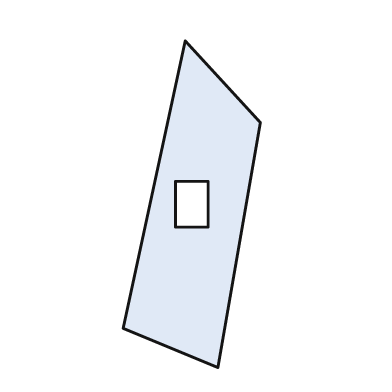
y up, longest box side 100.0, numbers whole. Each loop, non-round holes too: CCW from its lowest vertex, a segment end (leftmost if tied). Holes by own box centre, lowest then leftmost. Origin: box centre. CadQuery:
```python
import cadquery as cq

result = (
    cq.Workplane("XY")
    .moveTo(8.0, -50.0)
    .lineTo(21.0, 25.0)
    .lineTo(-2.0, 50.0)
    .lineTo(-21.0, -38.0)
    .close()
    .moveTo(-5.0, -7.0)
    .lineTo(5.0, -7.0)
    .lineTo(5.0, 7.0)
    .lineTo(-5.0, 7.0)
    .close()
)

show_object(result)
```